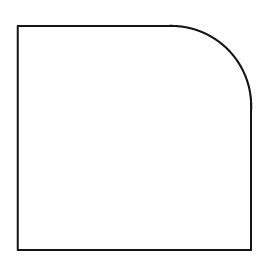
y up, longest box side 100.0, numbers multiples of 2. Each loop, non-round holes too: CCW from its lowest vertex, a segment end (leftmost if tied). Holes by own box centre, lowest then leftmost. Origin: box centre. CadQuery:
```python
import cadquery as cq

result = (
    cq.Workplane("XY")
    .moveTo(-50.0, -48.0)
    .lineTo(50.0, -48.0)
    .lineTo(50.0, 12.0)
    .threePointArc((40.0, 38.0), (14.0, 48.0))
    .lineTo(-50.0, 48.0)
    .close()
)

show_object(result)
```